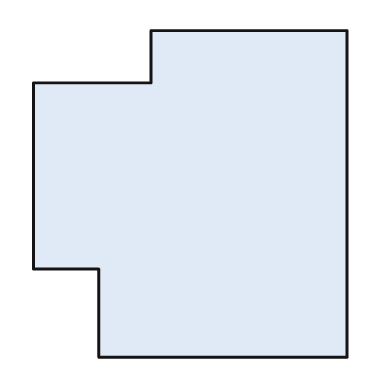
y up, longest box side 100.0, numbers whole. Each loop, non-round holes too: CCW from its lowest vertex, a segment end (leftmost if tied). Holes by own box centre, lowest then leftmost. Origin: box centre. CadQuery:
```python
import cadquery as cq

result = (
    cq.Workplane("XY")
    .moveTo(-28.0, -50.0)
    .lineTo(48.0, -50.0)
    .lineTo(48.0, 50.0)
    .lineTo(-12.0, 50.0)
    .lineTo(-12.0, 34.0)
    .lineTo(-48.0, 34.0)
    .lineTo(-48.0, -23.0)
    .lineTo(-28.0, -23.0)
    .close()
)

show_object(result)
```